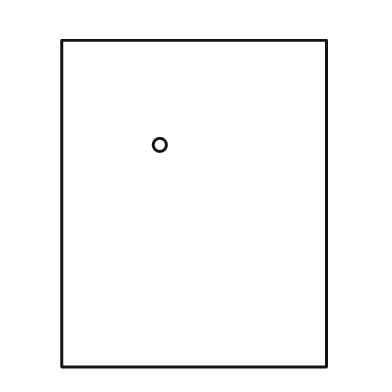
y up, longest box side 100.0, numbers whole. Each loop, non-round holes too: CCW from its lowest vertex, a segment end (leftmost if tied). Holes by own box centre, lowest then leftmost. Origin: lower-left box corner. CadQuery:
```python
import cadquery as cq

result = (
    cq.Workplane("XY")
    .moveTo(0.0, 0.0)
    .lineTo(81.0, 0.0)
    .lineTo(81.0, 100.0)
    .lineTo(0.0, 100.0)
    .close()
    .moveTo(30.0, 68.0)
    .circle(2.0)
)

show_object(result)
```